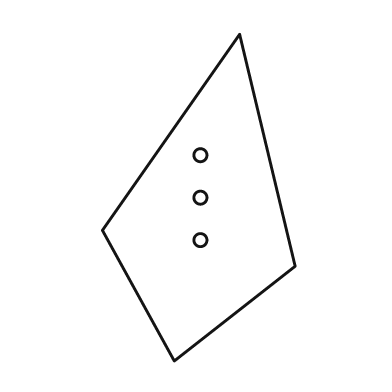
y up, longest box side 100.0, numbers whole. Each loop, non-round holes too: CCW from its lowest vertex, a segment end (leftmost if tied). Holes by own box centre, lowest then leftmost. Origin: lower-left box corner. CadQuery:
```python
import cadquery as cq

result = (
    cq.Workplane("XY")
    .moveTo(22.0, 0.0)
    .lineTo(59.0, 29.0)
    .lineTo(42.0, 100.0)
    .lineTo(0.0, 40.0)
    .close()
    .moveTo(30.0, 37.0)
    .circle(2.0)
    .moveTo(30.0, 50.0)
    .circle(2.0)
    .moveTo(30.0, 63.0)
    .circle(2.0)
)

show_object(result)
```